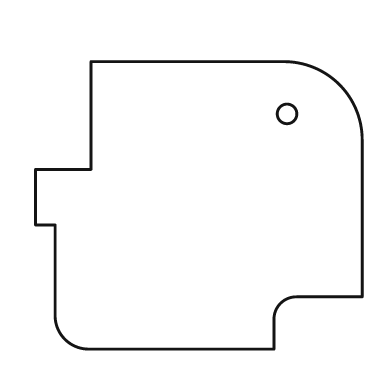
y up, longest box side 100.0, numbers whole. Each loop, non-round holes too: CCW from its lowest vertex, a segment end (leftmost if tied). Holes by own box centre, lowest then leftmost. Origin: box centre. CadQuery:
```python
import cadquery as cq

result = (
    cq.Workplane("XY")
    .moveTo(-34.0, -44.0)
    .lineTo(23.0, -44.0)
    .lineTo(23.0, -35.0)
    .threePointArc((25.0, -30.0), (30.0, -28.0))
    .lineTo(50.0, -28.0)
    .lineTo(50.0, 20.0)
    .threePointArc((43.0, 37.0), (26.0, 44.0))
    .lineTo(-33.0, 44.0)
    .lineTo(-33.0, 11.0)
    .lineTo(-50.0, 11.0)
    .lineTo(-50.0, -6.0)
    .lineTo(-44.0, -6.0)
    .lineTo(-44.0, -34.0)
    .threePointArc((-41.0, -41.0), (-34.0, -44.0))
    .close()
    .moveTo(27.0, 28.0)
    .circle(3.0)
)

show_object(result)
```